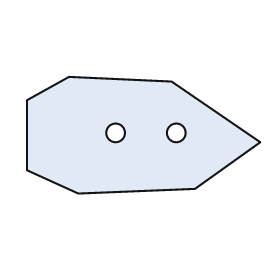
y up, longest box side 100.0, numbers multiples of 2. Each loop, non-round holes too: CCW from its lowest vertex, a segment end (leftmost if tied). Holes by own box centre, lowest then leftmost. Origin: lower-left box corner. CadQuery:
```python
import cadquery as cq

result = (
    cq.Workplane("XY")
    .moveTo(22.0, 0.0)
    .lineTo(72.0, 2.0)
    .lineTo(100.0, 22.0)
    .lineTo(62.0, 48.0)
    .lineTo(18.0, 50.0)
    .lineTo(0.0, 40.0)
    .lineTo(0.0, 10.0)
    .close()
    .moveTo(38.0, 26.0)
    .circle(4.0)
    .moveTo(64.0, 26.0)
    .circle(4.0)
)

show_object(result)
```